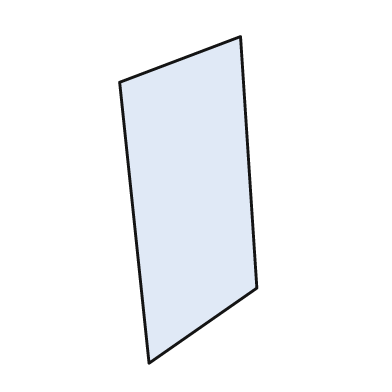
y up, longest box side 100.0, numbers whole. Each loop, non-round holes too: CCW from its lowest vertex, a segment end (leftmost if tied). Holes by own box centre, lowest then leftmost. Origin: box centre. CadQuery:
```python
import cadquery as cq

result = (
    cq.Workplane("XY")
    .moveTo(-12.0, -50.0)
    .lineTo(21.0, -27.0)
    .lineTo(16.0, 50.0)
    .lineTo(-21.0, 36.0)
    .close()
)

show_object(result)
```